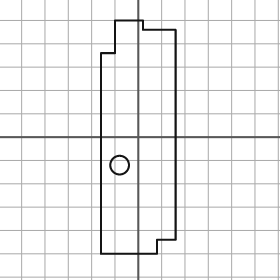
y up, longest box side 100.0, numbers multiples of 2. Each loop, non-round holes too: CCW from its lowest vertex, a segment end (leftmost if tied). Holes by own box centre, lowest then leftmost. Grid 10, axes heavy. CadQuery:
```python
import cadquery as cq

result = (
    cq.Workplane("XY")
    .moveTo(-16.0, -50.0)
    .lineTo(8.0, -50.0)
    .lineTo(8.0, -44.0)
    .lineTo(16.0, -44.0)
    .lineTo(16.0, 46.0)
    .lineTo(2.0, 46.0)
    .lineTo(2.0, 50.0)
    .lineTo(-10.0, 50.0)
    .lineTo(-10.0, 36.0)
    .lineTo(-16.0, 36.0)
    .close()
    .moveTo(-8.0, -12.0)
    .circle(4.0)
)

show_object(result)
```